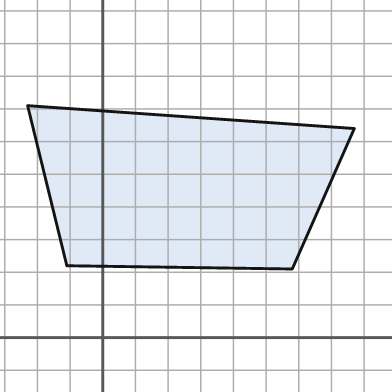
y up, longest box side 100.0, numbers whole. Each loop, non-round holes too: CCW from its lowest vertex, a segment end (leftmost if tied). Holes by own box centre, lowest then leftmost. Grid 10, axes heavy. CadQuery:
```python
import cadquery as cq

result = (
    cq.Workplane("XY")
    .moveTo(58.0, 21.0)
    .lineTo(77.0, 64.0)
    .lineTo(-23.0, 71.0)
    .lineTo(-11.0, 22.0)
    .close()
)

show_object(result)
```